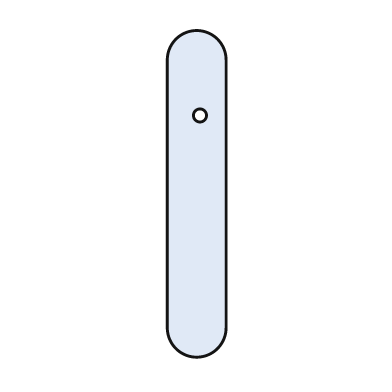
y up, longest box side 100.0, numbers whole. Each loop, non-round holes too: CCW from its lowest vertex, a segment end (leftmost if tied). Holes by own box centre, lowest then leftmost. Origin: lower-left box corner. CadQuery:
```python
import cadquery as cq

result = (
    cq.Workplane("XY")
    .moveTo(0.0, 9.0)
    .threePointArc((9.0, 0.0), (18.0, 9.0))
    .lineTo(18.0, 91.0)
    .threePointArc((9.0, 100.0), (0.0, 91.0))
    .close()
    .moveTo(10.0, 74.0)
    .circle(2.0)
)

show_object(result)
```